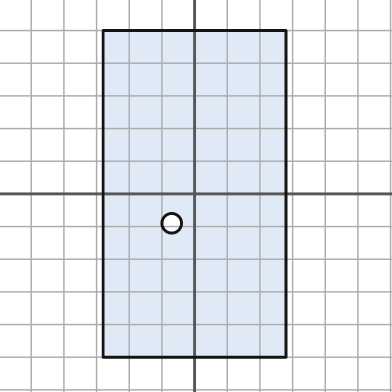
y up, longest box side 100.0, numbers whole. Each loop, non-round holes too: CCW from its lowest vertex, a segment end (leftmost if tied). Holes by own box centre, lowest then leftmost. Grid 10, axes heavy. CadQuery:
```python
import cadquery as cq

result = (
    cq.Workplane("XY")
    .moveTo(-28.0, -50.0)
    .lineTo(28.0, -50.0)
    .lineTo(28.0, 50.0)
    .lineTo(-28.0, 50.0)
    .close()
    .moveTo(-7.0, -9.0)
    .circle(3.0)
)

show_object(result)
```